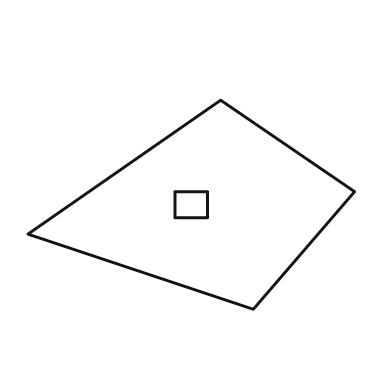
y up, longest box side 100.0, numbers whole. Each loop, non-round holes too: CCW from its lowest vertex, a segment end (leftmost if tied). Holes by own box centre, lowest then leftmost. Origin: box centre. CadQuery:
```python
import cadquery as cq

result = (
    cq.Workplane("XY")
    .moveTo(19.0, -32.0)
    .lineTo(50.0, 4.0)
    .lineTo(9.0, 32.0)
    .lineTo(-50.0, -9.0)
    .close()
    .moveTo(-5.0, -4.0)
    .lineTo(5.0, -4.0)
    .lineTo(5.0, 4.0)
    .lineTo(-5.0, 4.0)
    .close()
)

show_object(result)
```